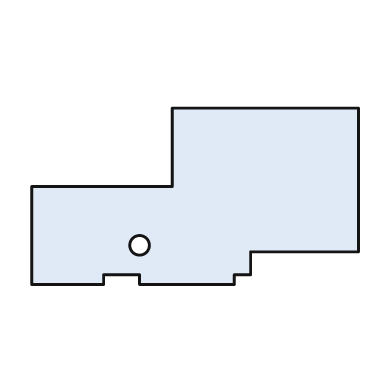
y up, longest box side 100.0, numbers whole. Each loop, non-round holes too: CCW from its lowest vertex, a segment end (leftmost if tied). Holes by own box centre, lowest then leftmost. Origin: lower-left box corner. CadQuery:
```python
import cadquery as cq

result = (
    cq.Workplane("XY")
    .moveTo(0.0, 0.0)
    .lineTo(22.0, 0.0)
    .lineTo(22.0, 3.0)
    .lineTo(33.0, 3.0)
    .lineTo(33.0, 0.0)
    .lineTo(62.0, 0.0)
    .lineTo(62.0, 3.0)
    .lineTo(67.0, 3.0)
    .lineTo(67.0, 10.0)
    .lineTo(100.0, 10.0)
    .lineTo(100.0, 54.0)
    .lineTo(43.0, 54.0)
    .lineTo(43.0, 30.0)
    .lineTo(0.0, 30.0)
    .close()
    .moveTo(33.0, 12.0)
    .circle(3.0)
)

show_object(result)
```